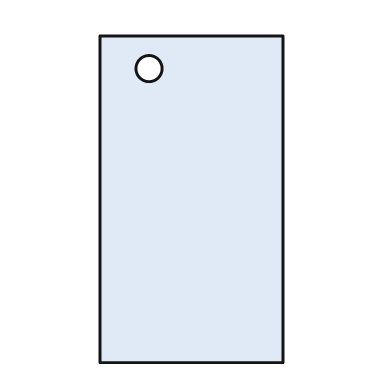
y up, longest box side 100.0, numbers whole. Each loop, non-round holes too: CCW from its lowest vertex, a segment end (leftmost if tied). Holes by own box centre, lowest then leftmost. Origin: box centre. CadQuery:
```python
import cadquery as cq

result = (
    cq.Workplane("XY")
    .moveTo(-28.0, -50.0)
    .lineTo(28.0, -50.0)
    .lineTo(28.0, 50.0)
    .lineTo(-28.0, 50.0)
    .close()
    .moveTo(-13.0, 40.0)
    .circle(4.0)
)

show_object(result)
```